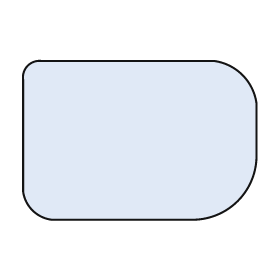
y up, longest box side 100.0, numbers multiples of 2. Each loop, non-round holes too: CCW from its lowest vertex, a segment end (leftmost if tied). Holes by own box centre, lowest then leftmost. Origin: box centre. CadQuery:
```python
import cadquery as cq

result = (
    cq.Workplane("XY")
    .moveTo(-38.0, -34.0)
    .lineTo(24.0, -34.0)
    .threePointArc((42.0, -26.0), (50.0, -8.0))
    .lineTo(50.0, 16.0)
    .threePointArc((44.0, 28.0), (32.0, 34.0))
    .lineTo(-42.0, 34.0)
    .threePointArc((-48.0, 32.0), (-50.0, 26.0))
    .lineTo(-50.0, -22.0)
    .threePointArc((-46.0, -30.0), (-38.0, -34.0))
    .close()
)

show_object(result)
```